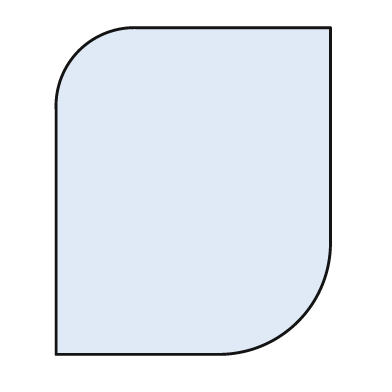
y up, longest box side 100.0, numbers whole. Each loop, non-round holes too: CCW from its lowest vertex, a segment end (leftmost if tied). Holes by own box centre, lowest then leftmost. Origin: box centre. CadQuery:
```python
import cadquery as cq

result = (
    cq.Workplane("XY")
    .moveTo(-42.0, -50.0)
    .lineTo(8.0, -50.0)
    .threePointArc((32.0, -40.0), (42.0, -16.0))
    .lineTo(42.0, 50.0)
    .lineTo(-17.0, 50.0)
    .threePointArc((-35.0, 43.0), (-42.0, 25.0))
    .close()
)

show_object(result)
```